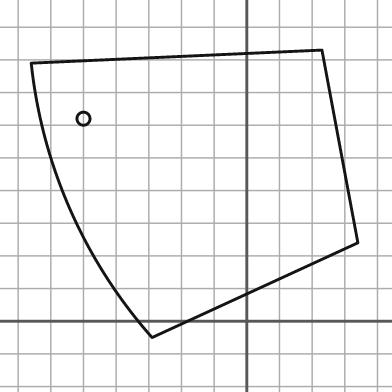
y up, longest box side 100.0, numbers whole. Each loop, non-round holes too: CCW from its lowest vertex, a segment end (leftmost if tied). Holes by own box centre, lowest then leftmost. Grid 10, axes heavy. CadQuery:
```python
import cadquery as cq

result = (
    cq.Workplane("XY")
    .moveTo(-29.0, -5.0)
    .lineTo(34.0, 24.0)
    .lineTo(23.0, 83.0)
    .lineTo(-66.0, 79.0)
    .threePointArc((-54.0, 34.0), (-29.0, -5.0))
    .close()
    .moveTo(-50.0, 62.0)
    .circle(2.0)
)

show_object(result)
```